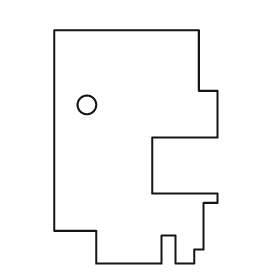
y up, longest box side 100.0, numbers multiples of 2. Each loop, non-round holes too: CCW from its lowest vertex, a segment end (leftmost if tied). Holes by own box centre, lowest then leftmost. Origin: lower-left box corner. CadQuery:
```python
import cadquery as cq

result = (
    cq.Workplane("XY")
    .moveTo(18.0, 0.0)
    .lineTo(46.0, 0.0)
    .lineTo(46.0, 12.0)
    .lineTo(52.0, 12.0)
    .lineTo(52.0, 0.0)
    .lineTo(60.0, 0.0)
    .lineTo(60.0, 6.0)
    .lineTo(64.0, 6.0)
    .lineTo(64.0, 26.0)
    .lineTo(70.0, 26.0)
    .lineTo(70.0, 30.0)
    .lineTo(42.0, 30.0)
    .lineTo(42.0, 54.0)
    .lineTo(70.0, 54.0)
    .lineTo(70.0, 74.0)
    .lineTo(62.0, 74.0)
    .lineTo(62.0, 100.0)
    .lineTo(0.0, 100.0)
    .lineTo(0.0, 14.0)
    .lineTo(18.0, 14.0)
    .close()
    .moveTo(14.0, 68.0)
    .circle(4.0)
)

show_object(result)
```